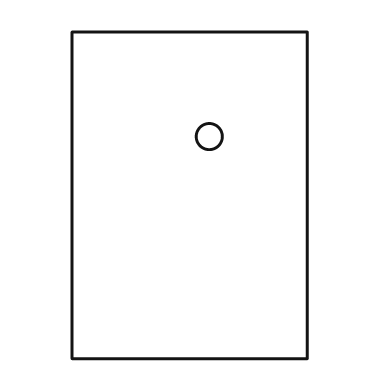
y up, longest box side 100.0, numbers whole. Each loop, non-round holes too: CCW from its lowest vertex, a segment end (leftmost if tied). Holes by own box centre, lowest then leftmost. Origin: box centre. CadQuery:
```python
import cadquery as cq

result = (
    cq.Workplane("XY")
    .moveTo(-36.0, -50.0)
    .lineTo(36.0, -50.0)
    .lineTo(36.0, 50.0)
    .lineTo(-36.0, 50.0)
    .close()
    .moveTo(6.0, 18.0)
    .circle(4.0)
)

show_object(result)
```